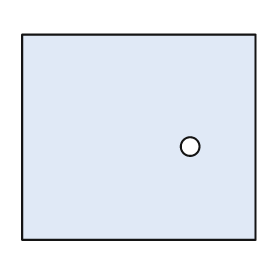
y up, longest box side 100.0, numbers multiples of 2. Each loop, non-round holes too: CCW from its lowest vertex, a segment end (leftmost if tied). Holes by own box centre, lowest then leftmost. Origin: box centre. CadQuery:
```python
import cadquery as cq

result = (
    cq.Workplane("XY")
    .moveTo(-50.0, -44.0)
    .lineTo(50.0, -44.0)
    .lineTo(50.0, 44.0)
    .lineTo(-50.0, 44.0)
    .close()
    .moveTo(22.0, -4.0)
    .circle(4.0)
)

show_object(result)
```